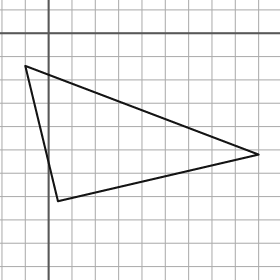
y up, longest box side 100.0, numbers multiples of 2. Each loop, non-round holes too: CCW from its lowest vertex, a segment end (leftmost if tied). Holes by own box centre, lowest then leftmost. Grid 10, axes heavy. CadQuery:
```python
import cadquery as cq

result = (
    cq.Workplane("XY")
    .moveTo(4.0, -72.0)
    .lineTo(90.0, -52.0)
    .lineTo(-10.0, -14.0)
    .close()
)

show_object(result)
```